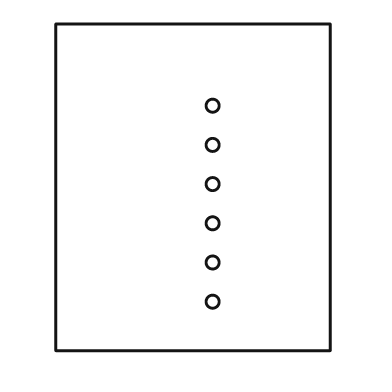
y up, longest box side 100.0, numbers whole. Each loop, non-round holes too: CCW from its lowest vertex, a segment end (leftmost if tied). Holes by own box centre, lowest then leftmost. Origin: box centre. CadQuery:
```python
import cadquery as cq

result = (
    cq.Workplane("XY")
    .moveTo(-42.0, -50.0)
    .lineTo(42.0, -50.0)
    .lineTo(42.0, 50.0)
    .lineTo(-42.0, 50.0)
    .close()
    .moveTo(6.0, -35.0)
    .circle(2.0)
    .moveTo(6.0, -23.0)
    .circle(2.0)
    .moveTo(6.0, -11.0)
    .circle(2.0)
    .moveTo(6.0, 1.0)
    .circle(2.0)
    .moveTo(6.0, 13.0)
    .circle(2.0)
    .moveTo(6.0, 25.0)
    .circle(2.0)
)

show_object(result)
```